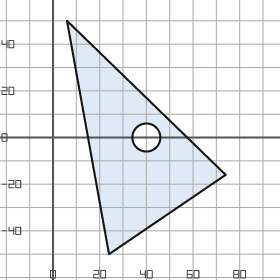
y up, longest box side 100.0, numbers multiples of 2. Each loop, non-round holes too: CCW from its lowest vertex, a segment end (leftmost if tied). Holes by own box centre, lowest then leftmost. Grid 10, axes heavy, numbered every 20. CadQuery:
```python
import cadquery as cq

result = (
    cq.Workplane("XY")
    .moveTo(24.0, -50.0)
    .lineTo(74.0, -16.0)
    .lineTo(6.0, 50.0)
    .close()
    .moveTo(40.0, 0.0)
    .circle(6.0)
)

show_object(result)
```